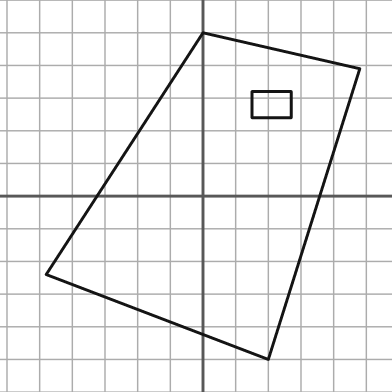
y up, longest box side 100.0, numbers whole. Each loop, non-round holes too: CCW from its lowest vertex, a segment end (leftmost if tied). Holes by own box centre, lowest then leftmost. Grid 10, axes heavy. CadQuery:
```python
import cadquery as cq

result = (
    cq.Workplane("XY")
    .moveTo(20.0, -50.0)
    .lineTo(48.0, 39.0)
    .lineTo(0.0, 50.0)
    .lineTo(-48.0, -24.0)
    .close()
    .moveTo(15.0, 24.0)
    .lineTo(27.0, 24.0)
    .lineTo(27.0, 32.0)
    .lineTo(15.0, 32.0)
    .close()
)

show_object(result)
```